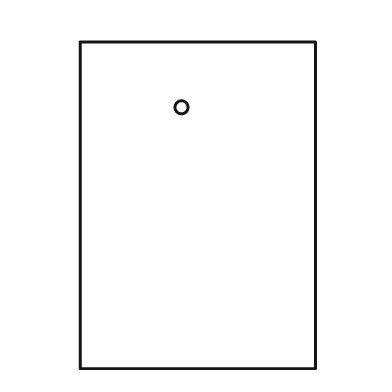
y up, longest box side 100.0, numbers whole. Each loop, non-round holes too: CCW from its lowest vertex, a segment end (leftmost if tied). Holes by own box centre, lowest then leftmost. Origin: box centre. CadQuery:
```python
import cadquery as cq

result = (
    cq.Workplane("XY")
    .moveTo(-36.0, -50.0)
    .lineTo(36.0, -50.0)
    .lineTo(36.0, 50.0)
    .lineTo(-36.0, 50.0)
    .close()
    .moveTo(-5.0, 30.0)
    .circle(2.0)
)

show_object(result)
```